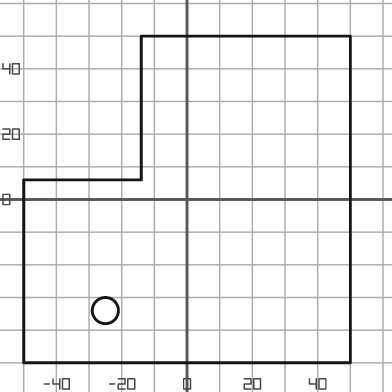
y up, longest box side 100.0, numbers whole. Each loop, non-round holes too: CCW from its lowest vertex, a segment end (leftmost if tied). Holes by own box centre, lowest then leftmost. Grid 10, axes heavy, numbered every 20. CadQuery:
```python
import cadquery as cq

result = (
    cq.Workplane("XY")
    .moveTo(-50.0, -50.0)
    .lineTo(50.0, -50.0)
    .lineTo(50.0, 50.0)
    .lineTo(-14.0, 50.0)
    .lineTo(-14.0, 6.0)
    .lineTo(-50.0, 6.0)
    .close()
    .moveTo(-25.0, -34.0)
    .circle(4.0)
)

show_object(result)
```